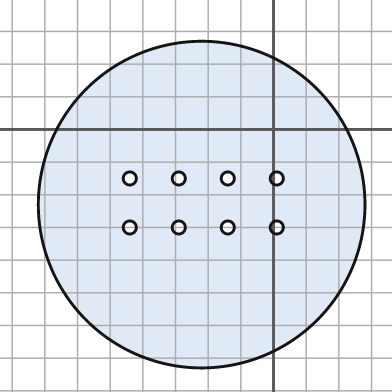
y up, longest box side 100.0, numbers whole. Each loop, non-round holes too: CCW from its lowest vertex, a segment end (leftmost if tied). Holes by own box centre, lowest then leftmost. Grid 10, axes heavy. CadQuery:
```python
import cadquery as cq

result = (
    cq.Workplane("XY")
    .moveTo(-22.0, -23.0)
    .circle(50.0)
    .moveTo(-44.0, -30.0)
    .circle(2.0)
    .moveTo(-29.0, -30.0)
    .circle(2.0)
    .moveTo(-14.0, -30.0)
    .circle(2.0)
    .moveTo(1.0, -30.0)
    .circle(2.0)
    .moveTo(-44.0, -15.0)
    .circle(2.0)
    .moveTo(-29.0, -15.0)
    .circle(2.0)
    .moveTo(-14.0, -15.0)
    .circle(2.0)
    .moveTo(1.0, -15.0)
    .circle(2.0)
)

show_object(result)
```